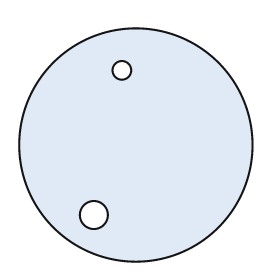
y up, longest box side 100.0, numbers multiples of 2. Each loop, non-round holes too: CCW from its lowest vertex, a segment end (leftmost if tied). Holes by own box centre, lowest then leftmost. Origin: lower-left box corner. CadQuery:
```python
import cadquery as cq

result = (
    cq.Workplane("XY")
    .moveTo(50.0, 50.0)
    .circle(50.0)
    .moveTo(32.0, 20.0)
    .circle(6.0)
    .moveTo(44.0, 82.0)
    .circle(4.0)
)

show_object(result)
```